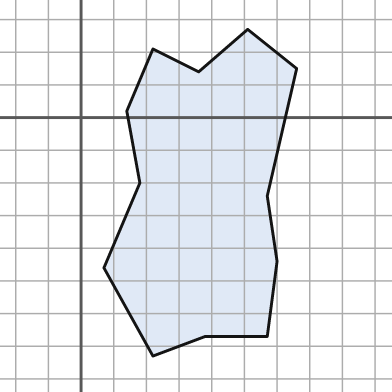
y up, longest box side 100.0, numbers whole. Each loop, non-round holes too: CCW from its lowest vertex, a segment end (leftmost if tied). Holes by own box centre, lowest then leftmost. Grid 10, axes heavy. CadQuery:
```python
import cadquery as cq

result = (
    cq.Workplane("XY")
    .moveTo(22.0, -73.0)
    .lineTo(38.0, -67.0)
    .lineTo(57.0, -67.0)
    .lineTo(60.0, -44.0)
    .lineTo(57.0, -24.0)
    .lineTo(66.0, 15.0)
    .lineTo(51.0, 27.0)
    .lineTo(36.0, 14.0)
    .lineTo(22.0, 21.0)
    .lineTo(14.0, 2.0)
    .lineTo(18.0, -20.0)
    .lineTo(7.0, -46.0)
    .close()
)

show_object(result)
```